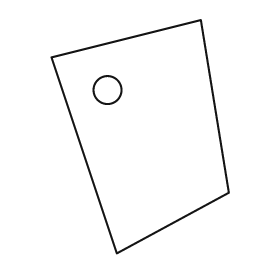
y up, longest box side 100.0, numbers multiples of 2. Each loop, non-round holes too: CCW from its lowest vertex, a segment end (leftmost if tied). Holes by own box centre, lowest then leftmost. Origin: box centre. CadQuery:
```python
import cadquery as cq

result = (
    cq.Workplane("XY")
    .moveTo(-10.0, -50.0)
    .lineTo(38.0, -24.0)
    .lineTo(26.0, 50.0)
    .lineTo(-38.0, 34.0)
    .close()
    .moveTo(-14.0, 20.0)
    .circle(6.0)
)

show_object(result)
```